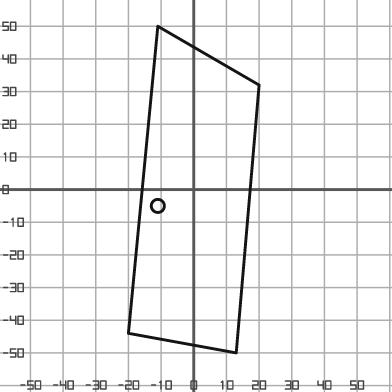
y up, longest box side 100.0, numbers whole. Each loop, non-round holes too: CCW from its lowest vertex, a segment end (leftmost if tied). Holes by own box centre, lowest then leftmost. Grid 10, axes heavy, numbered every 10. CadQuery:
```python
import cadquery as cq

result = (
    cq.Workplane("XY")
    .moveTo(13.0, -50.0)
    .lineTo(20.0, 32.0)
    .lineTo(-11.0, 50.0)
    .lineTo(-20.0, -44.0)
    .close()
    .moveTo(-11.0, -5.0)
    .circle(2.0)
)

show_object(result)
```